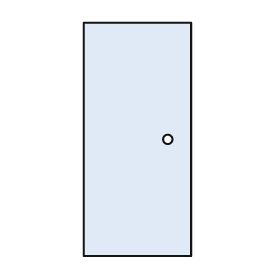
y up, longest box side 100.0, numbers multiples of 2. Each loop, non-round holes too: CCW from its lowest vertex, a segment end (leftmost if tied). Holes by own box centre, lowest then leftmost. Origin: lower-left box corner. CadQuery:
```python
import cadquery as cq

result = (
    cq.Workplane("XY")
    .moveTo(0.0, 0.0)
    .lineTo(46.0, 0.0)
    .lineTo(46.0, 100.0)
    .lineTo(0.0, 100.0)
    .close()
    .moveTo(36.0, 50.0)
    .circle(2.0)
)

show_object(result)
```